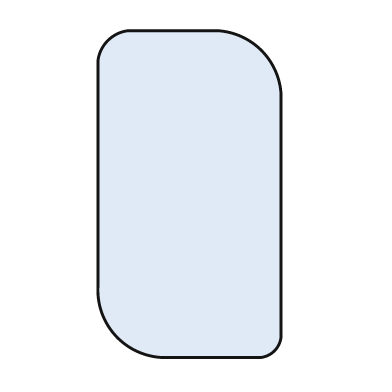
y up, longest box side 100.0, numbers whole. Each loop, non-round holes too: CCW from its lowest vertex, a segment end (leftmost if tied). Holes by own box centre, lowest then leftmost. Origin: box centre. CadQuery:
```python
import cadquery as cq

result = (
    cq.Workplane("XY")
    .moveTo(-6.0, -50.0)
    .lineTo(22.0, -50.0)
    .threePointArc((26.0, -48.0), (28.0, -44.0))
    .lineTo(28.0, 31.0)
    .threePointArc((22.0, 44.0), (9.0, 50.0))
    .lineTo(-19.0, 50.0)
    .threePointArc((-25.0, 47.0), (-28.0, 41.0))
    .lineTo(-28.0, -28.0)
    .threePointArc((-22.0, -44.0), (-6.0, -50.0))
    .close()
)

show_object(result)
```